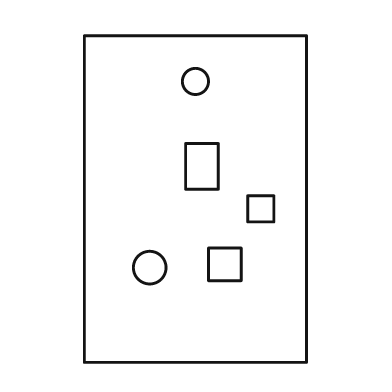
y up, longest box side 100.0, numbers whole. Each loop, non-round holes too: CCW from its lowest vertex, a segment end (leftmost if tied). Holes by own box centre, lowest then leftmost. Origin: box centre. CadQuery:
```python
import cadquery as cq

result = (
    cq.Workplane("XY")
    .moveTo(-34.0, -50.0)
    .lineTo(34.0, -50.0)
    .lineTo(34.0, 50.0)
    .lineTo(-34.0, 50.0)
    .close()
    .moveTo(-14.0, -21.0)
    .circle(5.0)
    .moveTo(4.0, -25.0)
    .lineTo(14.0, -25.0)
    .lineTo(14.0, -15.0)
    .lineTo(4.0, -15.0)
    .close()
    .moveTo(16.0, -7.0)
    .lineTo(24.0, -7.0)
    .lineTo(24.0, 1.0)
    .lineTo(16.0, 1.0)
    .close()
    .moveTo(-3.0, 3.0)
    .lineTo(7.0, 3.0)
    .lineTo(7.0, 17.0)
    .lineTo(-3.0, 17.0)
    .close()
    .moveTo(0.0, 36.0)
    .circle(4.0)
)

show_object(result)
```